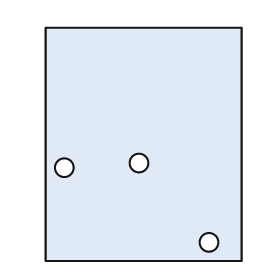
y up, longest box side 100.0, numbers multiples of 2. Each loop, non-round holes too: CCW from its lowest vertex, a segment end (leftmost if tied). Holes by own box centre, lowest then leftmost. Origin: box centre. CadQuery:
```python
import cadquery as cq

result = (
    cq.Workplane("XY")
    .moveTo(-42.0, -50.0)
    .lineTo(42.0, -50.0)
    .lineTo(42.0, 50.0)
    .lineTo(-42.0, 50.0)
    .close()
    .moveTo(28.0, -42.0)
    .circle(4.0)
    .moveTo(-34.0, -10.0)
    .circle(4.0)
    .moveTo(-2.0, -8.0)
    .circle(4.0)
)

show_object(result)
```